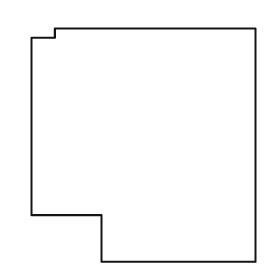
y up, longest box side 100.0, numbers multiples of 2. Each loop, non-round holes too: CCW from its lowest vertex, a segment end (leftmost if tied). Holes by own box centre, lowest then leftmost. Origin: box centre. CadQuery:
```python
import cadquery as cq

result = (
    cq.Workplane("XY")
    .moveTo(-18.0, -50.0)
    .lineTo(48.0, -50.0)
    .lineTo(48.0, 50.0)
    .lineTo(-38.0, 50.0)
    .lineTo(-38.0, 46.0)
    .lineTo(-48.0, 46.0)
    .lineTo(-48.0, -30.0)
    .lineTo(-18.0, -30.0)
    .close()
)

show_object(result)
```